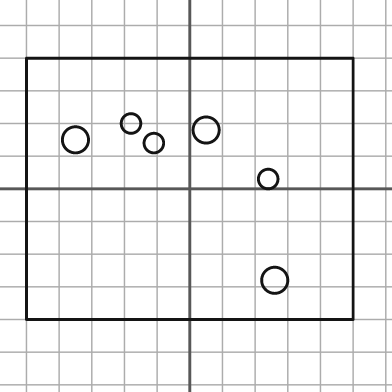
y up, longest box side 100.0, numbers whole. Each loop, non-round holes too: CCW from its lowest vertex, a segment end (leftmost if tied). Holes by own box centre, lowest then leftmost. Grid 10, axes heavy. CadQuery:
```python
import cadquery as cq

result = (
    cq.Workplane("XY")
    .moveTo(-50.0, -40.0)
    .lineTo(50.0, -40.0)
    .lineTo(50.0, 40.0)
    .lineTo(-50.0, 40.0)
    .close()
    .moveTo(26.0, -28.0)
    .circle(4.0)
    .moveTo(24.0, 3.0)
    .circle(3.0)
    .moveTo(-11.0, 14.0)
    .circle(3.0)
    .moveTo(-35.0, 15.0)
    .circle(4.0)
    .moveTo(5.0, 18.0)
    .circle(4.0)
    .moveTo(-18.0, 20.0)
    .circle(3.0)
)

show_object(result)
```